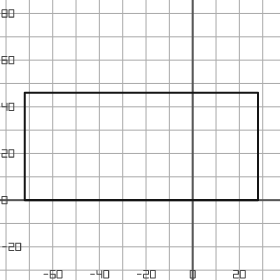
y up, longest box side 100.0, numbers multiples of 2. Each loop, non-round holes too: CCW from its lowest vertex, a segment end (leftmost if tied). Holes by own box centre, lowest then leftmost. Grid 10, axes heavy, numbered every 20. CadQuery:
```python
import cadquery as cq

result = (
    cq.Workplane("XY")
    .moveTo(-72.0, 0.0)
    .lineTo(28.0, 0.0)
    .lineTo(28.0, 46.0)
    .lineTo(-72.0, 46.0)
    .close()
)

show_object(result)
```